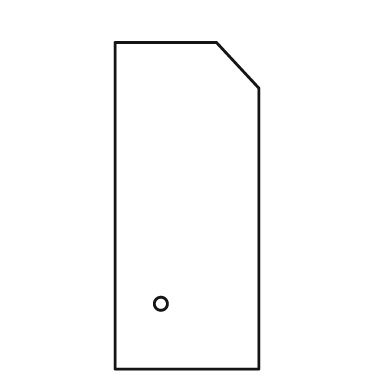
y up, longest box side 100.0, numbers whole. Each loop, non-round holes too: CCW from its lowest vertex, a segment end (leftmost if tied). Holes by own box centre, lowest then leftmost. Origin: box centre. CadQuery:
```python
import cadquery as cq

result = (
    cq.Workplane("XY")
    .moveTo(-22.0, -50.0)
    .lineTo(22.0, -50.0)
    .lineTo(22.0, 36.0)
    .lineTo(9.0, 50.0)
    .lineTo(-22.0, 50.0)
    .close()
    .moveTo(-8.0, -30.0)
    .circle(2.0)
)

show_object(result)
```